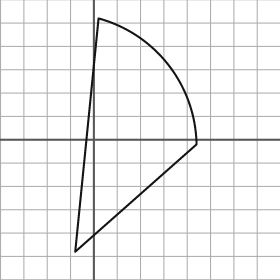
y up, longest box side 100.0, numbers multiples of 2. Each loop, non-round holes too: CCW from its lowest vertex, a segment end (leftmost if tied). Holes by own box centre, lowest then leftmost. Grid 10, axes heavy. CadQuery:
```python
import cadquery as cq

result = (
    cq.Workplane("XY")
    .moveTo(-8.0, -48.0)
    .lineTo(44.0, -2.0)
    .threePointArc((32.0, 32.0), (2.0, 52.0))
    .close()
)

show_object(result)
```